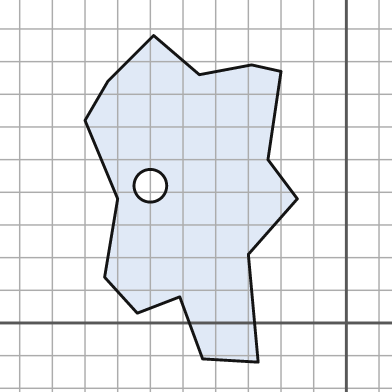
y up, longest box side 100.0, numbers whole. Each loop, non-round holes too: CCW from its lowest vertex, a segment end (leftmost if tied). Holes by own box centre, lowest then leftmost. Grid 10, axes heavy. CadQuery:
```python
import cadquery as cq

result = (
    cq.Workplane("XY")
    .moveTo(-27.0, -12.0)
    .lineTo(-30.0, 21.0)
    .lineTo(-15.0, 38.0)
    .lineTo(-24.0, 50.0)
    .lineTo(-20.0, 77.0)
    .lineTo(-29.0, 79.0)
    .lineTo(-45.0, 76.0)
    .lineTo(-59.0, 88.0)
    .lineTo(-73.0, 74.0)
    .lineTo(-80.0, 62.0)
    .lineTo(-70.0, 38.0)
    .lineTo(-74.0, 14.0)
    .lineTo(-64.0, 3.0)
    .lineTo(-51.0, 8.0)
    .lineTo(-44.0, -11.0)
    .close()
    .moveTo(-60.0, 42.0)
    .circle(5.0)
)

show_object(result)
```